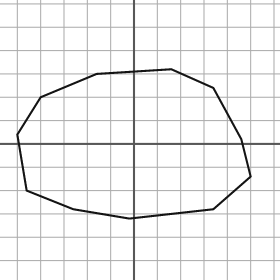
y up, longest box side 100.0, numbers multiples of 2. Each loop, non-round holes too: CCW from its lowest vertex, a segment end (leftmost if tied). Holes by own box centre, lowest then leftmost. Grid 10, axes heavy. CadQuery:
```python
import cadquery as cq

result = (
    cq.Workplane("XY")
    .moveTo(-2.0, -32.0)
    .lineTo(34.0, -28.0)
    .lineTo(50.0, -14.0)
    .lineTo(46.0, 2.0)
    .lineTo(34.0, 24.0)
    .lineTo(16.0, 32.0)
    .lineTo(-16.0, 30.0)
    .lineTo(-40.0, 20.0)
    .lineTo(-50.0, 4.0)
    .lineTo(-46.0, -20.0)
    .lineTo(-26.0, -28.0)
    .close()
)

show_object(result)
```